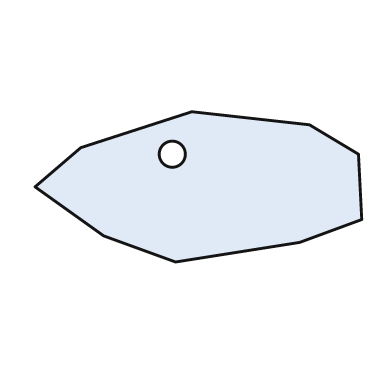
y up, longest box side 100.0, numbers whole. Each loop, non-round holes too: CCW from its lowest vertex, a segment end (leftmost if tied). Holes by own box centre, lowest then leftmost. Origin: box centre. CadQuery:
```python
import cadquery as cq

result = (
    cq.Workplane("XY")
    .moveTo(-7.0, -23.0)
    .lineTo(31.0, -17.0)
    .lineTo(50.0, -10.0)
    .lineTo(49.0, 10.0)
    .lineTo(34.0, 19.0)
    .lineTo(-2.0, 23.0)
    .lineTo(-36.0, 12.0)
    .lineTo(-50.0, 0.0)
    .lineTo(-29.0, -15.0)
    .close()
    .moveTo(-8.0, 10.0)
    .circle(4.0)
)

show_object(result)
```